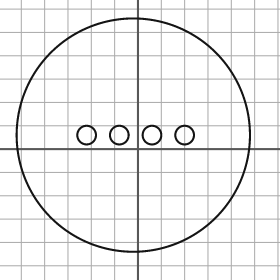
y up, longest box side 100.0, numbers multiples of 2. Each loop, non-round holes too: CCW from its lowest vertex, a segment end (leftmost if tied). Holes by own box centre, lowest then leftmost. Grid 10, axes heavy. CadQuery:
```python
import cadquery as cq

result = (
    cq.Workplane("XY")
    .moveTo(-2.0, 6.0)
    .circle(50.0)
    .moveTo(-22.0, 6.0)
    .circle(4.0)
    .moveTo(-8.0, 6.0)
    .circle(4.0)
    .moveTo(6.0, 6.0)
    .circle(4.0)
    .moveTo(20.0, 6.0)
    .circle(4.0)
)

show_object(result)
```